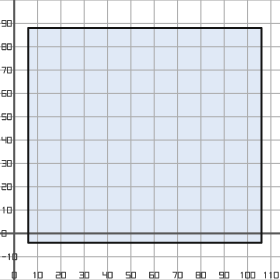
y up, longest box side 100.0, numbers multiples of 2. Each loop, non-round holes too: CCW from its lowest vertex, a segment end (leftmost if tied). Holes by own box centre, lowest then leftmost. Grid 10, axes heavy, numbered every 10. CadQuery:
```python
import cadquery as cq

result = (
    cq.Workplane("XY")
    .moveTo(6.0, -4.0)
    .lineTo(106.0, -4.0)
    .lineTo(106.0, 88.0)
    .lineTo(6.0, 88.0)
    .close()
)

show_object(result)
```